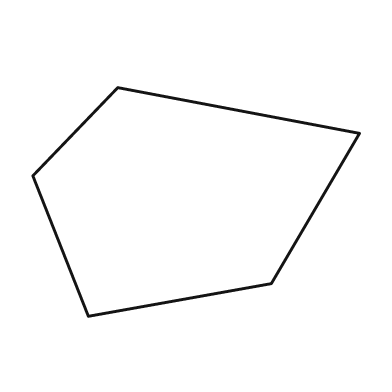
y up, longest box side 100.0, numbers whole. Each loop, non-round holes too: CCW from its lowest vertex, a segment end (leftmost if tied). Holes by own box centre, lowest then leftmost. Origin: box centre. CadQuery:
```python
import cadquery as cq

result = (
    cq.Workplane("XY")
    .moveTo(-33.0, -35.0)
    .lineTo(23.0, -25.0)
    .lineTo(50.0, 21.0)
    .lineTo(-24.0, 35.0)
    .lineTo(-50.0, 8.0)
    .close()
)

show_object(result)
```